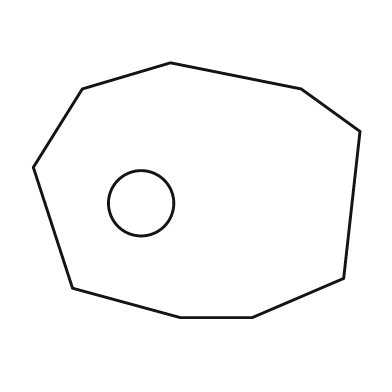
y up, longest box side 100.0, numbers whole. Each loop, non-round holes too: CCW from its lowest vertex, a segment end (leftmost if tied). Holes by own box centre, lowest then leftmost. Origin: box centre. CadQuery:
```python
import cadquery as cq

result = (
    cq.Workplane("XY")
    .moveTo(-5.0, -39.0)
    .lineTo(17.0, -39.0)
    .lineTo(45.0, -27.0)
    .lineTo(50.0, 18.0)
    .lineTo(32.0, 31.0)
    .lineTo(-8.0, 39.0)
    .lineTo(-35.0, 31.0)
    .lineTo(-50.0, 7.0)
    .lineTo(-38.0, -30.0)
    .close()
    .moveTo(-17.0, -4.0)
    .circle(10.0)
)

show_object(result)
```